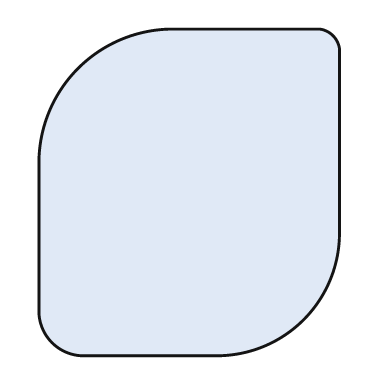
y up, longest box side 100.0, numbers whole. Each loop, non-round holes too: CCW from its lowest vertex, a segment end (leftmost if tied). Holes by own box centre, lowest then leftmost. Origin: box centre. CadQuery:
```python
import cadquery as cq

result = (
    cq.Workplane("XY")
    .moveTo(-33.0, -50.0)
    .lineTo(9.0, -50.0)
    .threePointArc((35.0, -39.0), (46.0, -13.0))
    .lineTo(46.0, 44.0)
    .threePointArc((44.0, 48.0), (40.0, 50.0))
    .lineTo(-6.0, 50.0)
    .threePointArc((-34.0, 38.0), (-46.0, 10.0))
    .lineTo(-46.0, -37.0)
    .threePointArc((-42.0, -46.0), (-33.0, -50.0))
    .close()
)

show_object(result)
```